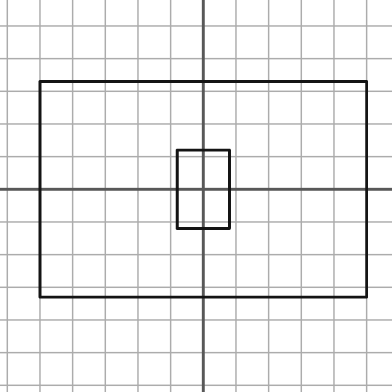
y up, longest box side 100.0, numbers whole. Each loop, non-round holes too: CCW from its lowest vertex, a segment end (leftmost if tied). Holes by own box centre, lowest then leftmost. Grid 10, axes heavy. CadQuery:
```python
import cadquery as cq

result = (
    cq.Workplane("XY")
    .moveTo(-50.0, -33.0)
    .lineTo(50.0, -33.0)
    .lineTo(50.0, 33.0)
    .lineTo(-50.0, 33.0)
    .close()
    .moveTo(-8.0, -12.0)
    .lineTo(8.0, -12.0)
    .lineTo(8.0, 12.0)
    .lineTo(-8.0, 12.0)
    .close()
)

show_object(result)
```